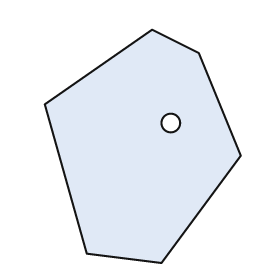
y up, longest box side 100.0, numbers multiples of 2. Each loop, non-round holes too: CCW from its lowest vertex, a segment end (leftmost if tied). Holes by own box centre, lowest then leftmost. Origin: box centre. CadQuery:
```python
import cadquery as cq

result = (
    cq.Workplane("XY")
    .moveTo(8.0, -50.0)
    .lineTo(42.0, -4.0)
    .lineTo(24.0, 40.0)
    .lineTo(4.0, 50.0)
    .lineTo(-42.0, 18.0)
    .lineTo(-24.0, -46.0)
    .close()
    .moveTo(12.0, 10.0)
    .circle(4.0)
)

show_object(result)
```